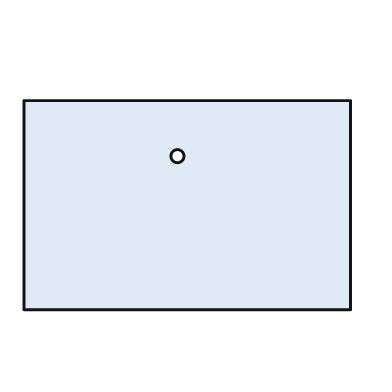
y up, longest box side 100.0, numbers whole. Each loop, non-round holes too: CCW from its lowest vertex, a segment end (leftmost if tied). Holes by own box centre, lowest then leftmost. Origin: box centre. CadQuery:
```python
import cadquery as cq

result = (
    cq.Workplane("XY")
    .moveTo(-50.0, -32.0)
    .lineTo(50.0, -32.0)
    .lineTo(50.0, 32.0)
    .lineTo(-50.0, 32.0)
    .close()
    .moveTo(-3.0, 15.0)
    .circle(2.0)
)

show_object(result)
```